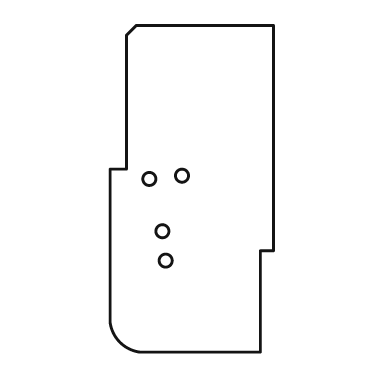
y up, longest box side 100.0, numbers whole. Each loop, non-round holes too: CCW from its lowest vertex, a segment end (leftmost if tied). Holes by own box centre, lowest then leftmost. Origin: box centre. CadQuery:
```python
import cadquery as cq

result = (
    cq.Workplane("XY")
    .moveTo(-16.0, -50.0)
    .lineTo(21.0, -50.0)
    .lineTo(21.0, -19.0)
    .lineTo(25.0, -19.0)
    .lineTo(25.0, 50.0)
    .lineTo(-17.0, 50.0)
    .lineTo(-20.0, 47.0)
    .lineTo(-20.0, 6.0)
    .lineTo(-25.0, 6.0)
    .lineTo(-25.0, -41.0)
    .threePointArc((-22.0, -47.0), (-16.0, -50.0))
    .close()
    .moveTo(-8.0, -22.0)
    .circle(2.0)
    .moveTo(-9.0, -13.0)
    .circle(2.0)
    .moveTo(-13.0, 3.0)
    .circle(2.0)
    .moveTo(-3.0, 4.0)
    .circle(2.0)
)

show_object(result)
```